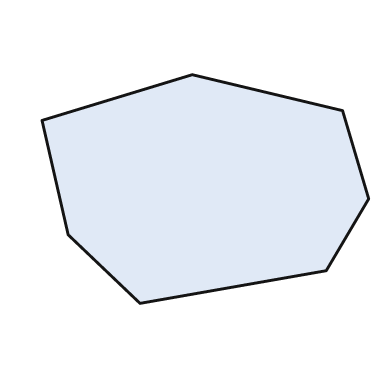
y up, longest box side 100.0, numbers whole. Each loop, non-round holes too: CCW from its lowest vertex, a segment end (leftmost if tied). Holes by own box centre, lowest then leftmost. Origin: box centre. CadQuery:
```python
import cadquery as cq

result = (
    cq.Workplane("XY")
    .moveTo(-20.0, -35.0)
    .lineTo(37.0, -25.0)
    .lineTo(50.0, -3.0)
    .lineTo(42.0, 24.0)
    .lineTo(-4.0, 35.0)
    .lineTo(-50.0, 21.0)
    .lineTo(-42.0, -14.0)
    .close()
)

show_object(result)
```